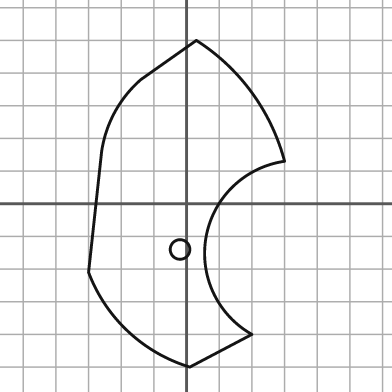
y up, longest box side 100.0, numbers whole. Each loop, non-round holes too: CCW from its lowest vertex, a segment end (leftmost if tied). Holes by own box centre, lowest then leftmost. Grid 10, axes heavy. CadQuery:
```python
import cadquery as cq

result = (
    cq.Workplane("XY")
    .moveTo(1.0, -50.0)
    .lineTo(20.0, -40.0)
    .threePointArc((6.0, -10.0), (30.0, 13.0))
    .threePointArc((20.0, 34.0), (3.0, 50.0))
    .lineTo(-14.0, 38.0)
    .threePointArc((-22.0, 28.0), (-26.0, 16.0))
    .lineTo(-30.0, -21.0)
    .threePointArc((-18.0, -39.0), (1.0, -50.0))
    .close()
    .moveTo(-2.0, -14.0)
    .circle(3.0)
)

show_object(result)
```